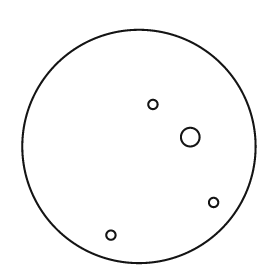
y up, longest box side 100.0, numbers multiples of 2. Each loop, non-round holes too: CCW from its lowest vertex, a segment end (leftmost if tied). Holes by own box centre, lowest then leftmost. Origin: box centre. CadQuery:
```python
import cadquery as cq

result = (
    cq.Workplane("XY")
    .moveTo(0.0, 0.0)
    .circle(50.0)
    .moveTo(-12.0, -38.0)
    .circle(2.0)
    .moveTo(32.0, -24.0)
    .circle(2.0)
    .moveTo(22.0, 4.0)
    .circle(4.0)
    .moveTo(6.0, 18.0)
    .circle(2.0)
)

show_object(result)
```